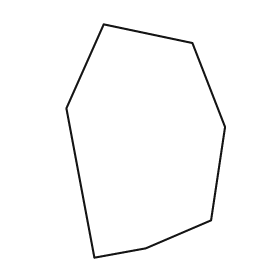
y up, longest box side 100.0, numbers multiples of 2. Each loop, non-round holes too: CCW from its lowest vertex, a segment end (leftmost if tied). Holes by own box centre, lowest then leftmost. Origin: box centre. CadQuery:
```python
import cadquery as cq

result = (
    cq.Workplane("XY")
    .moveTo(-22.0, -50.0)
    .lineTo(0.0, -46.0)
    .lineTo(28.0, -34.0)
    .lineTo(34.0, 6.0)
    .lineTo(20.0, 42.0)
    .lineTo(-18.0, 50.0)
    .lineTo(-34.0, 14.0)
    .close()
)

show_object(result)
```